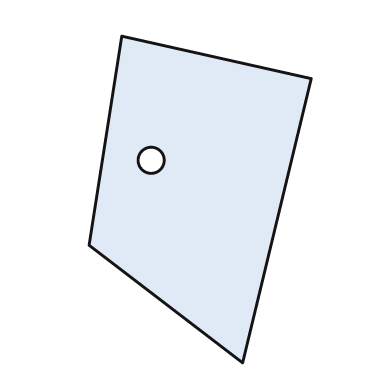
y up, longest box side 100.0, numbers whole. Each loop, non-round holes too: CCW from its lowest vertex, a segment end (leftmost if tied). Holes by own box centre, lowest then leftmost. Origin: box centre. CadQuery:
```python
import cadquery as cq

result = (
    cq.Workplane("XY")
    .moveTo(13.0, -50.0)
    .lineTo(34.0, 37.0)
    .lineTo(-24.0, 50.0)
    .lineTo(-34.0, -14.0)
    .close()
    .moveTo(-15.0, 12.0)
    .circle(4.0)
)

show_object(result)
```